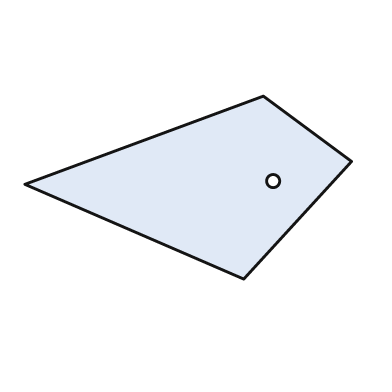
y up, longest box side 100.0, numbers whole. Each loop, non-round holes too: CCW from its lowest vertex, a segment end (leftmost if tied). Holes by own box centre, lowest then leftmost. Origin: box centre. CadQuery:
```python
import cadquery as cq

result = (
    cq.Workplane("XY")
    .moveTo(17.0, -28.0)
    .lineTo(50.0, 8.0)
    .lineTo(23.0, 28.0)
    .lineTo(-50.0, 1.0)
    .close()
    .moveTo(26.0, 2.0)
    .circle(2.0)
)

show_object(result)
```